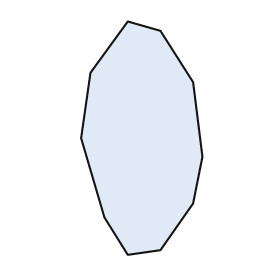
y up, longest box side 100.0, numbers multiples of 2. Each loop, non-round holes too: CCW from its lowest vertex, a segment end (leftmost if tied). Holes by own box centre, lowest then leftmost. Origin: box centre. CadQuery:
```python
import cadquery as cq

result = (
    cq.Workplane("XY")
    .moveTo(-6.0, -50.0)
    .lineTo(8.0, -48.0)
    .lineTo(22.0, -28.0)
    .lineTo(26.0, -8.0)
    .lineTo(22.0, 24.0)
    .lineTo(8.0, 46.0)
    .lineTo(-6.0, 50.0)
    .lineTo(-22.0, 28.0)
    .lineTo(-26.0, 0.0)
    .lineTo(-16.0, -34.0)
    .close()
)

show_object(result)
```